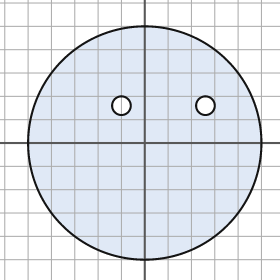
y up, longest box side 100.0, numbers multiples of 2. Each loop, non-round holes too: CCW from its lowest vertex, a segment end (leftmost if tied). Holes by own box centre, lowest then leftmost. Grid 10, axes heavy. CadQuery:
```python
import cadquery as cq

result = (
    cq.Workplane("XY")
    .moveTo(0.0, 0.0)
    .circle(50.0)
    .moveTo(-10.0, 16.0)
    .circle(4.0)
    .moveTo(26.0, 16.0)
    .circle(4.0)
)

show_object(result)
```